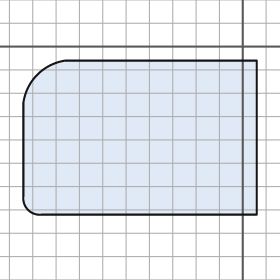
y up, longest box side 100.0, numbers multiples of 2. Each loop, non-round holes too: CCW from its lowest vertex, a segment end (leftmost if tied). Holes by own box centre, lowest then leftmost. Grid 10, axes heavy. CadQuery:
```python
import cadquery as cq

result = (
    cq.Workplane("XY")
    .moveTo(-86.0, -72.0)
    .lineTo(6.0, -72.0)
    .lineTo(6.0, -6.0)
    .lineTo(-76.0, -6.0)
    .threePointArc((-88.0, -12.0), (-94.0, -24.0))
    .lineTo(-94.0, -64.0)
    .threePointArc((-92.0, -70.0), (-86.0, -72.0))
    .close()
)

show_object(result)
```